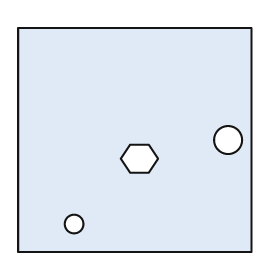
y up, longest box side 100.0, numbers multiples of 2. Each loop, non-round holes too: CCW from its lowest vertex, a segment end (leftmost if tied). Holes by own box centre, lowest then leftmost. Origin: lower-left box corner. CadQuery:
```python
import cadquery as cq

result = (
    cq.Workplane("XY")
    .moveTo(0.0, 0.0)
    .lineTo(100.0, 0.0)
    .lineTo(100.0, 96.0)
    .lineTo(0.0, 96.0)
    .close()
    .moveTo(24.0, 12.0)
    .circle(4.0)
    .moveTo(48.0, 34.0)
    .lineTo(56.0, 34.0)
    .lineTo(60.0, 40.0)
    .lineTo(56.0, 46.0)
    .lineTo(48.0, 46.0)
    .lineTo(44.0, 40.0)
    .close()
    .moveTo(90.0, 48.0)
    .circle(6.0)
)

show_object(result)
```